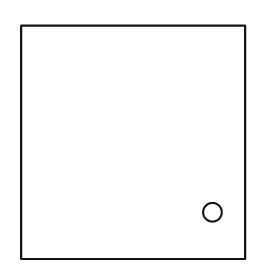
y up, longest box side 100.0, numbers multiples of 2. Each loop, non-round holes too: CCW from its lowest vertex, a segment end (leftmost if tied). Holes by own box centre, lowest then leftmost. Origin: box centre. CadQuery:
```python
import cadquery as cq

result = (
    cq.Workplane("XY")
    .moveTo(-48.0, -50.0)
    .lineTo(48.0, -50.0)
    .lineTo(48.0, 50.0)
    .lineTo(-48.0, 50.0)
    .close()
    .moveTo(34.0, -30.0)
    .circle(4.0)
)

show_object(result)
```